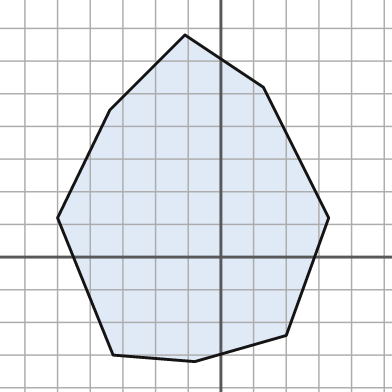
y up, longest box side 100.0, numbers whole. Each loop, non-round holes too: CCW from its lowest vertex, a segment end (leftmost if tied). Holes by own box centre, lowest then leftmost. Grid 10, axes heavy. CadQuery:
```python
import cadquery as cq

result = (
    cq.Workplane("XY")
    .moveTo(-8.0, -32.0)
    .lineTo(20.0, -24.0)
    .lineTo(33.0, 12.0)
    .lineTo(13.0, 52.0)
    .lineTo(-11.0, 68.0)
    .lineTo(-34.0, 45.0)
    .lineTo(-50.0, 12.0)
    .lineTo(-33.0, -30.0)
    .close()
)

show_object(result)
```